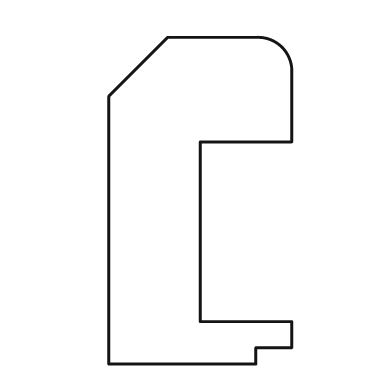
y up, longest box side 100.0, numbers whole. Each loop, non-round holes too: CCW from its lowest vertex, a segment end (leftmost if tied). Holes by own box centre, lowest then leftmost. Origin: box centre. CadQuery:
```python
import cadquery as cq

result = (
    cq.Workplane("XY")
    .moveTo(-28.0, -50.0)
    .lineTo(17.0, -50.0)
    .lineTo(17.0, -45.0)
    .lineTo(28.0, -45.0)
    .lineTo(28.0, -37.0)
    .lineTo(0.0, -37.0)
    .lineTo(0.0, 18.0)
    .lineTo(28.0, 18.0)
    .lineTo(28.0, 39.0)
    .threePointArc((25.0, 47.0), (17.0, 50.0))
    .lineTo(-10.0, 50.0)
    .lineTo(-28.0, 32.0)
    .close()
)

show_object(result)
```